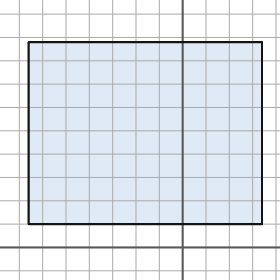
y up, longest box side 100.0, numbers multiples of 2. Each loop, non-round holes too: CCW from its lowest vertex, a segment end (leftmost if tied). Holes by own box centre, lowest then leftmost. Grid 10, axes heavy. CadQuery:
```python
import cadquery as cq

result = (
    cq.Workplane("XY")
    .moveTo(-66.0, 10.0)
    .lineTo(34.0, 10.0)
    .lineTo(34.0, 88.0)
    .lineTo(-66.0, 88.0)
    .close()
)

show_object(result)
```